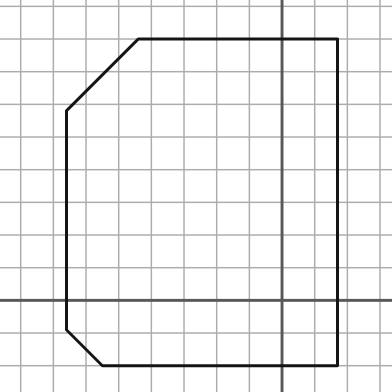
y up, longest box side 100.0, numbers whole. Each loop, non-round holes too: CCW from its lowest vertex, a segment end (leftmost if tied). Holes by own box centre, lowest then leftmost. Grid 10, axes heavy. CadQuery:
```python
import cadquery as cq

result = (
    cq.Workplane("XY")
    .moveTo(-55.0, -20.0)
    .lineTo(17.0, -20.0)
    .lineTo(17.0, 80.0)
    .lineTo(-44.0, 80.0)
    .lineTo(-66.0, 58.0)
    .lineTo(-66.0, -9.0)
    .close()
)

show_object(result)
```